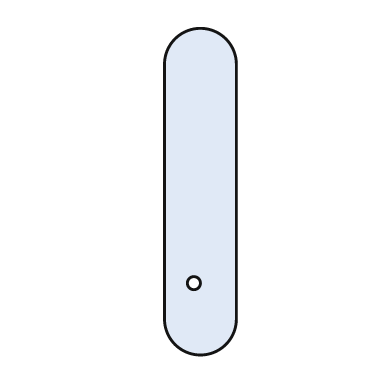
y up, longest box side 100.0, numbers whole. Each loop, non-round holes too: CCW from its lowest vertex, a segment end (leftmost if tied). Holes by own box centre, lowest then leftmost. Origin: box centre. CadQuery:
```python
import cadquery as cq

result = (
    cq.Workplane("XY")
    .moveTo(-11.0, -39.0)
    .threePointArc((0.0, -50.0), (11.0, -39.0))
    .lineTo(11.0, 39.0)
    .threePointArc((0.0, 50.0), (-11.0, 39.0))
    .close()
    .moveTo(-2.0, -28.0)
    .circle(2.0)
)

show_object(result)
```